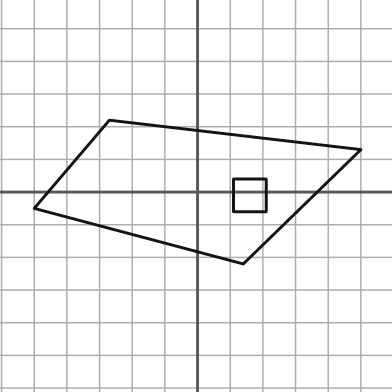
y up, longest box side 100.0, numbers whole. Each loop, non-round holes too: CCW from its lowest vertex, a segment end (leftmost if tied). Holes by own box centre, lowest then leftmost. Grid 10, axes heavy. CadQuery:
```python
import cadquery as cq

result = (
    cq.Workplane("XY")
    .moveTo(14.0, -22.0)
    .lineTo(50.0, 13.0)
    .lineTo(-27.0, 22.0)
    .lineTo(-50.0, -5.0)
    .close()
    .moveTo(11.0, -6.0)
    .lineTo(21.0, -6.0)
    .lineTo(21.0, 4.0)
    .lineTo(11.0, 4.0)
    .close()
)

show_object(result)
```